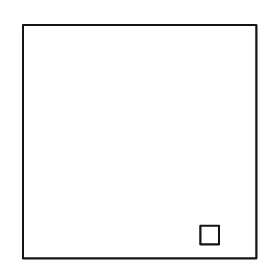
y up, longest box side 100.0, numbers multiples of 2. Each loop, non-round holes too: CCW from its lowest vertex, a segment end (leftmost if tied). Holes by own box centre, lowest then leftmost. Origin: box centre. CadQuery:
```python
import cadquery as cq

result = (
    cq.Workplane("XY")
    .moveTo(-50.0, -50.0)
    .lineTo(50.0, -50.0)
    .lineTo(50.0, 50.0)
    .lineTo(-50.0, 50.0)
    .close()
    .moveTo(26.0, -44.0)
    .lineTo(34.0, -44.0)
    .lineTo(34.0, -36.0)
    .lineTo(26.0, -36.0)
    .close()
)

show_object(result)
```